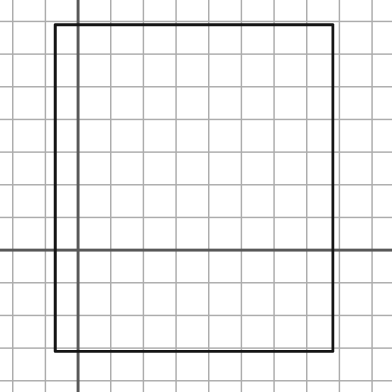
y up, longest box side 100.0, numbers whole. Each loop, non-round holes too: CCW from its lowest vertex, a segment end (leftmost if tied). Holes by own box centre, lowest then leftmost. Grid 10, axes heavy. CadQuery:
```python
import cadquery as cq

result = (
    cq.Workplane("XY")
    .moveTo(-7.0, -31.0)
    .lineTo(78.0, -31.0)
    .lineTo(78.0, 69.0)
    .lineTo(-7.0, 69.0)
    .close()
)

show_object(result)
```